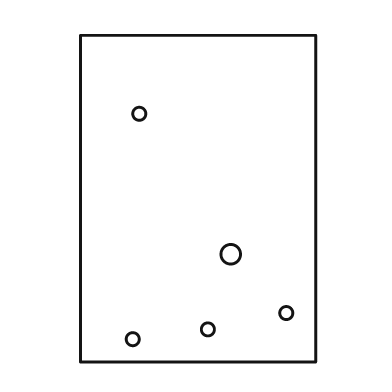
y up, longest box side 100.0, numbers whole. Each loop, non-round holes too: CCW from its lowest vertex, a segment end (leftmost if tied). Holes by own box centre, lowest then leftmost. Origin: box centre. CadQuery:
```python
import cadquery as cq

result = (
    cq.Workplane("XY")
    .moveTo(-36.0, -50.0)
    .lineTo(36.0, -50.0)
    .lineTo(36.0, 50.0)
    .lineTo(-36.0, 50.0)
    .close()
    .moveTo(-20.0, -43.0)
    .circle(2.0)
    .moveTo(3.0, -40.0)
    .circle(2.0)
    .moveTo(27.0, -35.0)
    .circle(2.0)
    .moveTo(10.0, -17.0)
    .circle(3.0)
    .moveTo(-18.0, 26.0)
    .circle(2.0)
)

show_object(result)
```